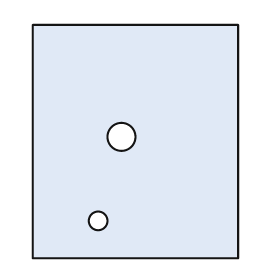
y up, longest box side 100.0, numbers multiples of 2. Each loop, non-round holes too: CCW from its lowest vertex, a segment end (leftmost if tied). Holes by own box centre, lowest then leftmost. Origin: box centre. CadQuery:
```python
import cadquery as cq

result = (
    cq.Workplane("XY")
    .moveTo(-44.0, -50.0)
    .lineTo(44.0, -50.0)
    .lineTo(44.0, 50.0)
    .lineTo(-44.0, 50.0)
    .close()
    .moveTo(-16.0, -34.0)
    .circle(4.0)
    .moveTo(-6.0, 2.0)
    .circle(6.0)
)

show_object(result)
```